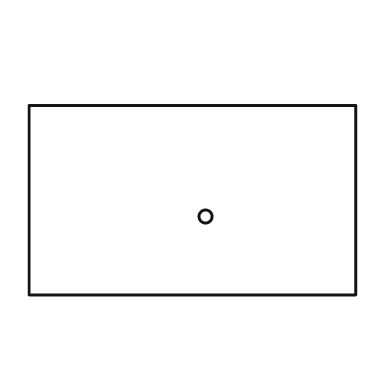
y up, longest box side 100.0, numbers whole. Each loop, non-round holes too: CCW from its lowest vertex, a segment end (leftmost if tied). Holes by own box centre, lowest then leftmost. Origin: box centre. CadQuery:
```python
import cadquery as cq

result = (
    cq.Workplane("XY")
    .moveTo(-50.0, -29.0)
    .lineTo(50.0, -29.0)
    .lineTo(50.0, 29.0)
    .lineTo(-50.0, 29.0)
    .close()
    .moveTo(4.0, -5.0)
    .circle(2.0)
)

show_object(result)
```